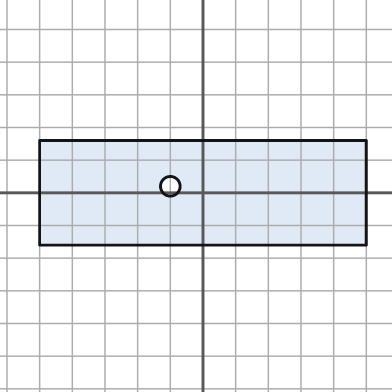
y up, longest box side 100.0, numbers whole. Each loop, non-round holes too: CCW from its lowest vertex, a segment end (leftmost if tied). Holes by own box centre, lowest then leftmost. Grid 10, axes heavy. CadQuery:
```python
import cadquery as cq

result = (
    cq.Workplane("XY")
    .moveTo(-50.0, -16.0)
    .lineTo(50.0, -16.0)
    .lineTo(50.0, 16.0)
    .lineTo(-50.0, 16.0)
    .close()
    .moveTo(-10.0, 2.0)
    .circle(3.0)
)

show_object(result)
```